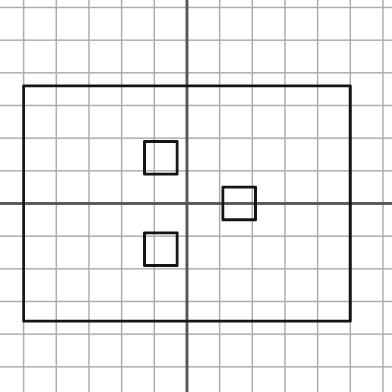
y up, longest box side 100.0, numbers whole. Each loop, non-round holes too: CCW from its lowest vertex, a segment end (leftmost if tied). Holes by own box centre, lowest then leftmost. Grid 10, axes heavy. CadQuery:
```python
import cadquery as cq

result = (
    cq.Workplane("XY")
    .moveTo(-50.0, -36.0)
    .lineTo(50.0, -36.0)
    .lineTo(50.0, 36.0)
    .lineTo(-50.0, 36.0)
    .close()
    .moveTo(-13.0, -19.0)
    .lineTo(-3.0, -19.0)
    .lineTo(-3.0, -9.0)
    .lineTo(-13.0, -9.0)
    .close()
    .moveTo(11.0, -5.0)
    .lineTo(21.0, -5.0)
    .lineTo(21.0, 5.0)
    .lineTo(11.0, 5.0)
    .close()
    .moveTo(-13.0, 9.0)
    .lineTo(-3.0, 9.0)
    .lineTo(-3.0, 19.0)
    .lineTo(-13.0, 19.0)
    .close()
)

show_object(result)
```